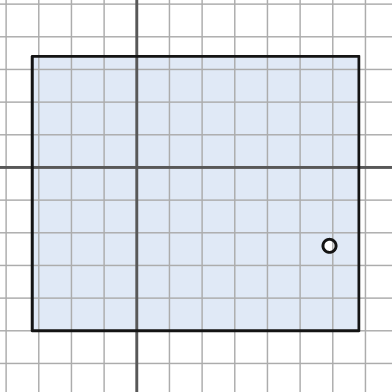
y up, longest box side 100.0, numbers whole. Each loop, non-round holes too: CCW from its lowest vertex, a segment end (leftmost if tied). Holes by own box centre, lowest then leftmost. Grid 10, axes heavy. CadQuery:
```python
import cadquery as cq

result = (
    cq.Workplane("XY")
    .moveTo(-32.0, -50.0)
    .lineTo(68.0, -50.0)
    .lineTo(68.0, 34.0)
    .lineTo(-32.0, 34.0)
    .close()
    .moveTo(59.0, -24.0)
    .circle(2.0)
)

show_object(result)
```